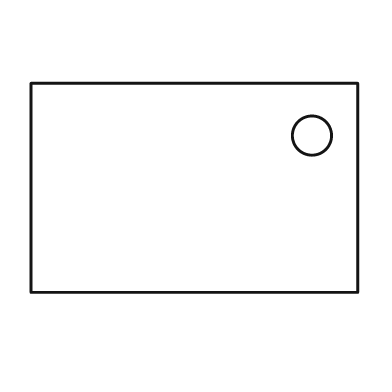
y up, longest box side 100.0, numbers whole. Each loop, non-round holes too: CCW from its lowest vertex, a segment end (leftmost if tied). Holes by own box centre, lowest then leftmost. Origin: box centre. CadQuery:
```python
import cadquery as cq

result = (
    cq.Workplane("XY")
    .moveTo(-50.0, -32.0)
    .lineTo(50.0, -32.0)
    .lineTo(50.0, 32.0)
    .lineTo(-50.0, 32.0)
    .close()
    .moveTo(36.0, 16.0)
    .circle(6.0)
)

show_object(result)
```